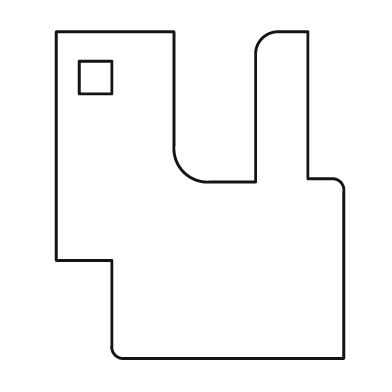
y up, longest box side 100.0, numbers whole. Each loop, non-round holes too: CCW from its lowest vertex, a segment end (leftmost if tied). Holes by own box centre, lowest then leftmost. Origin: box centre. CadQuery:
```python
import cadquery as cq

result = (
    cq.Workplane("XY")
    .moveTo(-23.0, -50.0)
    .lineTo(44.0, -50.0)
    .lineTo(44.0, 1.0)
    .threePointArc((43.0, 4.0), (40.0, 5.0))
    .lineTo(33.0, 5.0)
    .lineTo(33.0, 50.0)
    .lineTo(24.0, 50.0)
    .threePointArc((19.0, 48.0), (17.0, 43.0))
    .lineTo(17.0, 4.0)
    .lineTo(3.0, 4.0)
    .threePointArc((-5.0, 7.0), (-8.0, 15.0))
    .lineTo(-8.0, 50.0)
    .lineTo(-44.0, 50.0)
    .lineTo(-44.0, -20.0)
    .lineTo(-27.0, -20.0)
    .lineTo(-27.0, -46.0)
    .threePointArc((-26.0, -49.0), (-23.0, -50.0))
    .close()
    .moveTo(-37.0, 31.0)
    .lineTo(-27.0, 31.0)
    .lineTo(-27.0, 41.0)
    .lineTo(-37.0, 41.0)
    .close()
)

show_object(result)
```